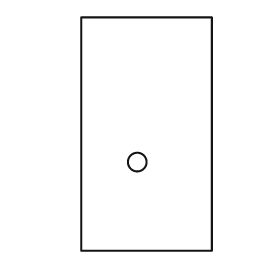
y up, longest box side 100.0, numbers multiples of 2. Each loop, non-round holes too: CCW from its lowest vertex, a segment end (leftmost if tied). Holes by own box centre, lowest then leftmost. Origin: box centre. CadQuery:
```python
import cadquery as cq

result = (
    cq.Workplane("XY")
    .moveTo(-28.0, -50.0)
    .lineTo(28.0, -50.0)
    .lineTo(28.0, 50.0)
    .lineTo(-28.0, 50.0)
    .close()
    .moveTo(-4.0, -12.0)
    .circle(4.0)
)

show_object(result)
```